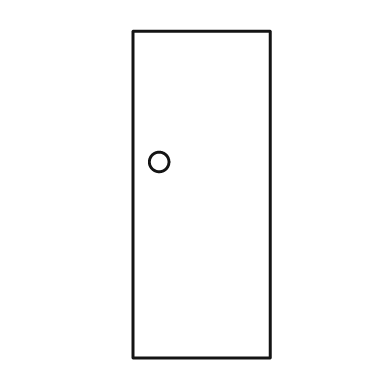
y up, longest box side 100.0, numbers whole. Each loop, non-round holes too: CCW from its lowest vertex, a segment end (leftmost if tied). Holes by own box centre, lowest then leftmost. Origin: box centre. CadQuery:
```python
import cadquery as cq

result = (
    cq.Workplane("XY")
    .moveTo(-21.0, -50.0)
    .lineTo(21.0, -50.0)
    .lineTo(21.0, 50.0)
    .lineTo(-21.0, 50.0)
    .close()
    .moveTo(-13.0, 10.0)
    .circle(3.0)
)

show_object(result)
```